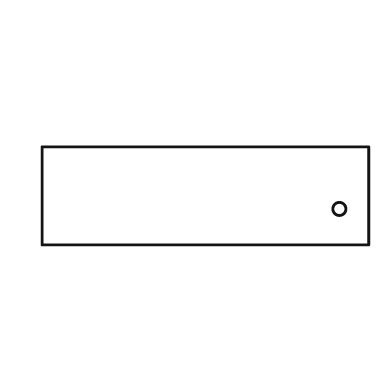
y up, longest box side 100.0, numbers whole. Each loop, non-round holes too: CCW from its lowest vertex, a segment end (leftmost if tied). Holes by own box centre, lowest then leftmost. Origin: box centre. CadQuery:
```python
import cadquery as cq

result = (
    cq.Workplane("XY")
    .moveTo(-50.0, -15.0)
    .lineTo(50.0, -15.0)
    .lineTo(50.0, 15.0)
    .lineTo(-50.0, 15.0)
    .close()
    .moveTo(41.0, -4.0)
    .circle(2.0)
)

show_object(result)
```